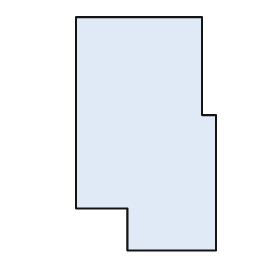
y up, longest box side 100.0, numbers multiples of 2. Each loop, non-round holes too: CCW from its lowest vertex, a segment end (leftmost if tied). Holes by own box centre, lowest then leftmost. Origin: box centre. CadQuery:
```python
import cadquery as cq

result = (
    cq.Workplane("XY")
    .moveTo(-8.0, -50.0)
    .lineTo(30.0, -50.0)
    .lineTo(30.0, 8.0)
    .lineTo(24.0, 8.0)
    .lineTo(24.0, 50.0)
    .lineTo(-30.0, 50.0)
    .lineTo(-30.0, -32.0)
    .lineTo(-8.0, -32.0)
    .close()
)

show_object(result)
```